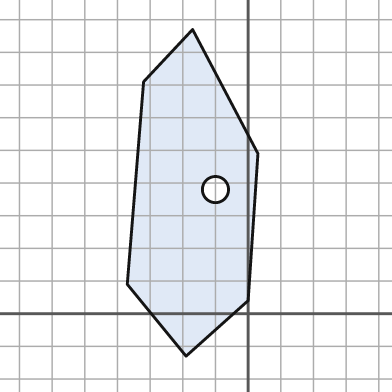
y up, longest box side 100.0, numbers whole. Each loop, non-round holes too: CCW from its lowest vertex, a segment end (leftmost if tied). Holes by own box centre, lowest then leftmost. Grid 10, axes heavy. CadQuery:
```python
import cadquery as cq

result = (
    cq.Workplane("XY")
    .moveTo(-19.0, -13.0)
    .lineTo(0.0, 4.0)
    .lineTo(3.0, 49.0)
    .lineTo(-17.0, 87.0)
    .lineTo(-32.0, 71.0)
    .lineTo(-37.0, 9.0)
    .close()
    .moveTo(-10.0, 38.0)
    .circle(4.0)
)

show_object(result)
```